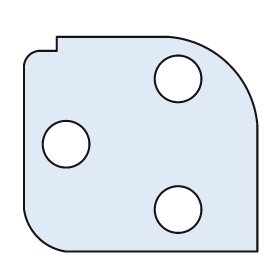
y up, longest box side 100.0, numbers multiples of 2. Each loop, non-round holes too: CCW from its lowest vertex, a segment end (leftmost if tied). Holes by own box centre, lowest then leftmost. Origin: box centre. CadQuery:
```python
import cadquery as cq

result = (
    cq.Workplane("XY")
    .moveTo(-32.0, -46.0)
    .lineTo(50.0, -46.0)
    .lineTo(50.0, 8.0)
    .threePointArc((38.0, 34.0), (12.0, 46.0))
    .lineTo(-36.0, 46.0)
    .lineTo(-36.0, 40.0)
    .lineTo(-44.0, 40.0)
    .threePointArc((-48.0, 38.0), (-50.0, 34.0))
    .lineTo(-50.0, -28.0)
    .threePointArc((-44.0, -40.0), (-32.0, -46.0))
    .close()
    .moveTo(16.0, -28.0)
    .circle(10.0)
    .moveTo(-32.0, 0.0)
    .circle(10.0)
    .moveTo(16.0, 28.0)
    .circle(10.0)
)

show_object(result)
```